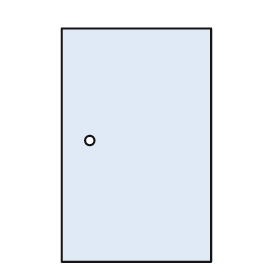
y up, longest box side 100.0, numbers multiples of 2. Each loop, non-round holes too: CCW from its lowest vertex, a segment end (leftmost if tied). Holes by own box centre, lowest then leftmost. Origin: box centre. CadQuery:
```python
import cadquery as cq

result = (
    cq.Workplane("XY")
    .moveTo(-32.0, -50.0)
    .lineTo(32.0, -50.0)
    .lineTo(32.0, 50.0)
    .lineTo(-32.0, 50.0)
    .close()
    .moveTo(-20.0, 2.0)
    .circle(2.0)
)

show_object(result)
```